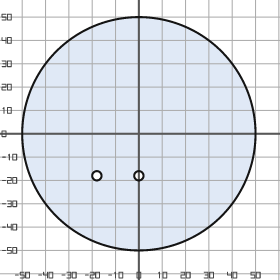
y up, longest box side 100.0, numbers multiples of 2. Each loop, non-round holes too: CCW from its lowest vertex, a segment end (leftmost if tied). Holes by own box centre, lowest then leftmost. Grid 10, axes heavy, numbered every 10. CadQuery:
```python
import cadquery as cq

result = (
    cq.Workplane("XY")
    .moveTo(0.0, 0.0)
    .circle(50.0)
    .moveTo(-18.0, -18.0)
    .circle(2.0)
    .moveTo(0.0, -18.0)
    .circle(2.0)
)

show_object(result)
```